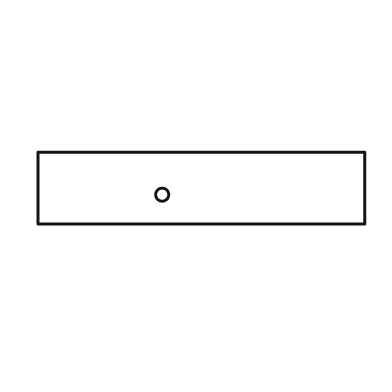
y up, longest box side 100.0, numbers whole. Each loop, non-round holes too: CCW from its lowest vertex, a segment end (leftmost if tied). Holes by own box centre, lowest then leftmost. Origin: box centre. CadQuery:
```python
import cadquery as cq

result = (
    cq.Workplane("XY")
    .moveTo(-50.0, -11.0)
    .lineTo(50.0, -11.0)
    .lineTo(50.0, 11.0)
    .lineTo(-50.0, 11.0)
    .close()
    .moveTo(-12.0, -2.0)
    .circle(2.0)
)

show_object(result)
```